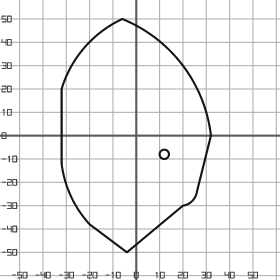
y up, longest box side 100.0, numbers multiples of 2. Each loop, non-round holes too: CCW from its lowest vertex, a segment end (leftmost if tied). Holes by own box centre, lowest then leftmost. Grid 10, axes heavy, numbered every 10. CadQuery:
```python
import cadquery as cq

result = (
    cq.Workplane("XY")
    .moveTo(-4.0, -50.0)
    .lineTo(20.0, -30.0)
    .threePointArc((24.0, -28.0), (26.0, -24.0))
    .lineTo(32.0, 0.0)
    .threePointArc((20.0, 30.0), (-6.0, 50.0))
    .threePointArc((-22.0, 38.0), (-32.0, 20.0))
    .lineTo(-32.0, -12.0)
    .threePointArc((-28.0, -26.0), (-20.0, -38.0))
    .close()
    .moveTo(12.0, -8.0)
    .circle(2.0)
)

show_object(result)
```